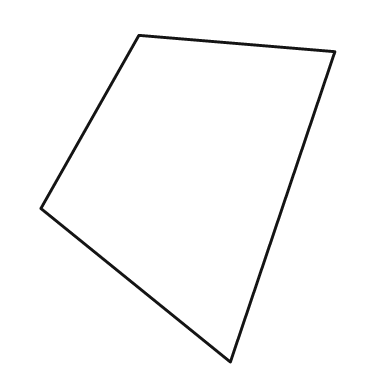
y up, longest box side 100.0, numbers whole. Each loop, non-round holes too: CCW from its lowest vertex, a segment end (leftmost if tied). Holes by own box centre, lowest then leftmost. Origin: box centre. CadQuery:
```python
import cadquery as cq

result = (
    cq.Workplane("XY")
    .moveTo(13.0, -50.0)
    .lineTo(45.0, 45.0)
    .lineTo(-15.0, 50.0)
    .lineTo(-45.0, -3.0)
    .close()
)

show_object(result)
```